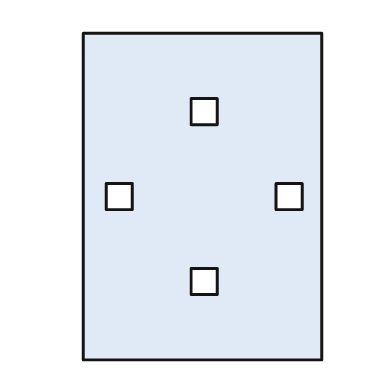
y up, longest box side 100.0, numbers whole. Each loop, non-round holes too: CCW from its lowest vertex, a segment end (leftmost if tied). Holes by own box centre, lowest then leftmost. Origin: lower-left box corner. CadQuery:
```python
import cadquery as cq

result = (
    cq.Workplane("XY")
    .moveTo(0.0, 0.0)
    .lineTo(73.0, 0.0)
    .lineTo(73.0, 100.0)
    .lineTo(0.0, 100.0)
    .close()
    .moveTo(33.0, 20.0)
    .lineTo(41.0, 20.0)
    .lineTo(41.0, 28.0)
    .lineTo(33.0, 28.0)
    .close()
    .moveTo(7.0, 46.0)
    .lineTo(15.0, 46.0)
    .lineTo(15.0, 54.0)
    .lineTo(7.0, 54.0)
    .close()
    .moveTo(59.0, 46.0)
    .lineTo(67.0, 46.0)
    .lineTo(67.0, 54.0)
    .lineTo(59.0, 54.0)
    .close()
    .moveTo(33.0, 72.0)
    .lineTo(41.0, 72.0)
    .lineTo(41.0, 80.0)
    .lineTo(33.0, 80.0)
    .close()
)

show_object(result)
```